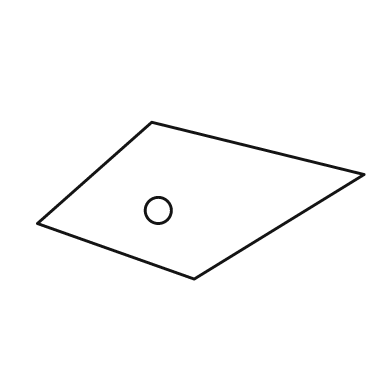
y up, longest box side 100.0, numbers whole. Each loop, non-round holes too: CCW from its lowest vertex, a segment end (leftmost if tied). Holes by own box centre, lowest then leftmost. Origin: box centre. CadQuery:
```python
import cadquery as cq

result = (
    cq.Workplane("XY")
    .moveTo(-2.0, -24.0)
    .lineTo(50.0, 8.0)
    .lineTo(-15.0, 24.0)
    .lineTo(-50.0, -7.0)
    .close()
    .moveTo(-13.0, -3.0)
    .circle(4.0)
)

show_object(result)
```